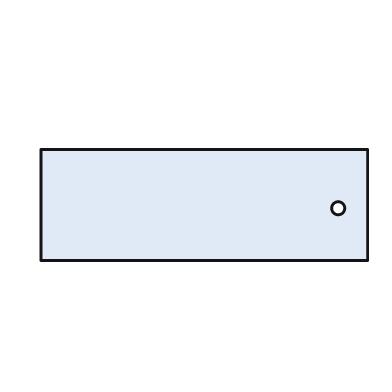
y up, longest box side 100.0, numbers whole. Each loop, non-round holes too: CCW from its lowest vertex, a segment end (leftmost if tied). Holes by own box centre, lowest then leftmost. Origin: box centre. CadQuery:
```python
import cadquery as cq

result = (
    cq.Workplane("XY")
    .moveTo(-50.0, -17.0)
    .lineTo(50.0, -17.0)
    .lineTo(50.0, 17.0)
    .lineTo(-50.0, 17.0)
    .close()
    .moveTo(41.0, -1.0)
    .circle(2.0)
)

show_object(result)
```